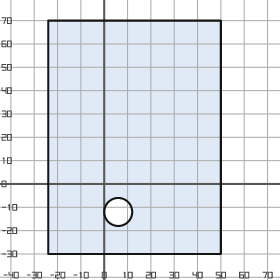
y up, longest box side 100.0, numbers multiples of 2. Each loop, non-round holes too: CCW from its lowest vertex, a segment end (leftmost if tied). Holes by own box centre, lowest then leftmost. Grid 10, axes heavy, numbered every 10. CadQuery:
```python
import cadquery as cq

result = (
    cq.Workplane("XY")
    .moveTo(-24.0, -30.0)
    .lineTo(50.0, -30.0)
    .lineTo(50.0, 70.0)
    .lineTo(-24.0, 70.0)
    .close()
    .moveTo(6.0, -12.0)
    .circle(6.0)
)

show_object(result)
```